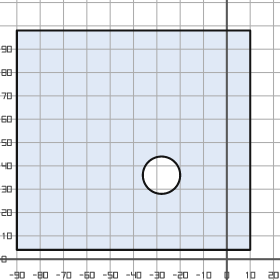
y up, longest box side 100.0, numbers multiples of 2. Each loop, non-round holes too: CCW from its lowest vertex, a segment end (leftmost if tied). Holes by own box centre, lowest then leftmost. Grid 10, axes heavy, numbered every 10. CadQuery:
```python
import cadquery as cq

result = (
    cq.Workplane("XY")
    .moveTo(-90.0, 4.0)
    .lineTo(10.0, 4.0)
    .lineTo(10.0, 98.0)
    .lineTo(-90.0, 98.0)
    .close()
    .moveTo(-28.0, 36.0)
    .circle(8.0)
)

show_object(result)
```